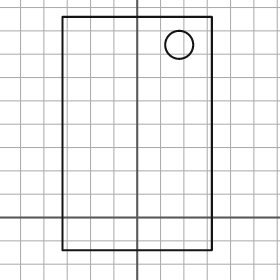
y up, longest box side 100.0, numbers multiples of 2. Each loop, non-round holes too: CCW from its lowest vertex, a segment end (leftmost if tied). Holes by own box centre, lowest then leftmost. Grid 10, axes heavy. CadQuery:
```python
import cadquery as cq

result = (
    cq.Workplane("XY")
    .moveTo(-32.0, -14.0)
    .lineTo(32.0, -14.0)
    .lineTo(32.0, 86.0)
    .lineTo(-32.0, 86.0)
    .close()
    .moveTo(18.0, 74.0)
    .circle(6.0)
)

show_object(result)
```